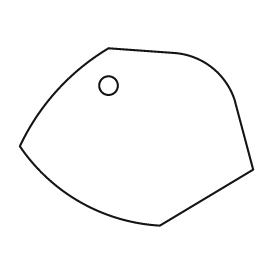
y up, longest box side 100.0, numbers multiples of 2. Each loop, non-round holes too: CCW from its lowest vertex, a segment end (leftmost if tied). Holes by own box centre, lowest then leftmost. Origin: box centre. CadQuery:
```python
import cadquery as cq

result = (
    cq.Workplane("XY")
    .moveTo(10.0, -38.0)
    .lineTo(50.0, -14.0)
    .lineTo(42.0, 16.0)
    .threePointArc((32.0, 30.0), (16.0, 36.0))
    .lineTo(-12.0, 38.0)
    .threePointArc((-34.0, 20.0), (-50.0, -4.0))
    .threePointArc((-24.0, -28.0), (10.0, -38.0))
    .close()
    .moveTo(-12.0, 22.0)
    .circle(4.0)
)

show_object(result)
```